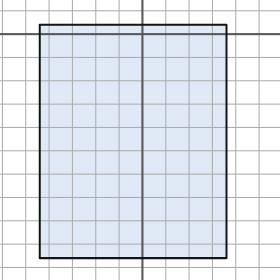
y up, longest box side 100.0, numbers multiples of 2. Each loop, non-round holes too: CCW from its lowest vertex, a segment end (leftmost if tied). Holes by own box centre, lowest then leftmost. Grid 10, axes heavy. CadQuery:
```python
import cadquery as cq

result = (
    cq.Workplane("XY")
    .moveTo(-44.0, -96.0)
    .lineTo(36.0, -96.0)
    .lineTo(36.0, 4.0)
    .lineTo(-44.0, 4.0)
    .close()
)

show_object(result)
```